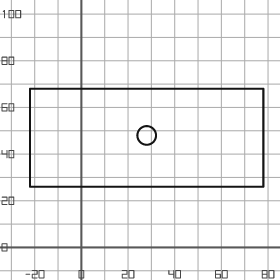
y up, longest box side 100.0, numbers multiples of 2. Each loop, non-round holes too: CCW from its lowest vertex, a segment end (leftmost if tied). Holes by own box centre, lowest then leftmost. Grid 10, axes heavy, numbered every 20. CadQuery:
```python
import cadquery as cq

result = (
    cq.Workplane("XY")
    .moveTo(-22.0, 26.0)
    .lineTo(78.0, 26.0)
    .lineTo(78.0, 68.0)
    .lineTo(-22.0, 68.0)
    .close()
    .moveTo(28.0, 48.0)
    .circle(4.0)
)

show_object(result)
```